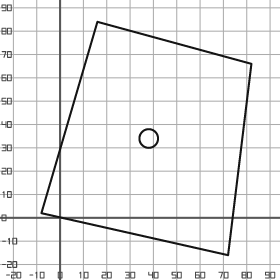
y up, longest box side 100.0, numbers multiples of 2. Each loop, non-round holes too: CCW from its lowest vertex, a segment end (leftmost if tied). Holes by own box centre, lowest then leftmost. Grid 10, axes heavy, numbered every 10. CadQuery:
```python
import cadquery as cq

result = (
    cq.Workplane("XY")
    .moveTo(72.0, -16.0)
    .lineTo(82.0, 66.0)
    .lineTo(16.0, 84.0)
    .lineTo(-8.0, 2.0)
    .close()
    .moveTo(38.0, 34.0)
    .circle(4.0)
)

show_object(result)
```